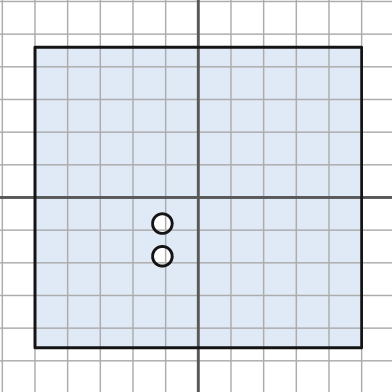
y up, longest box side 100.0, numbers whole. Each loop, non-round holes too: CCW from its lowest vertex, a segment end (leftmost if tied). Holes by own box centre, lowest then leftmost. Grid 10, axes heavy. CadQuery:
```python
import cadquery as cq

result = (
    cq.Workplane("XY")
    .moveTo(-50.0, -46.0)
    .lineTo(50.0, -46.0)
    .lineTo(50.0, 46.0)
    .lineTo(-50.0, 46.0)
    .close()
    .moveTo(-11.0, -18.0)
    .circle(3.0)
    .moveTo(-11.0, -8.0)
    .circle(3.0)
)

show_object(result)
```